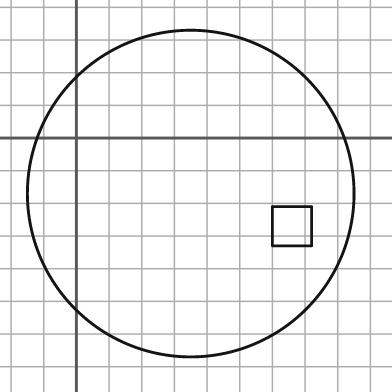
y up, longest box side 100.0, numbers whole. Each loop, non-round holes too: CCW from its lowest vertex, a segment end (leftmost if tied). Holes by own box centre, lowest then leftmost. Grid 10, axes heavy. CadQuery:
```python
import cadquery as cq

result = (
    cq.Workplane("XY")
    .moveTo(35.0, -17.0)
    .circle(50.0)
    .moveTo(60.0, -33.0)
    .lineTo(72.0, -33.0)
    .lineTo(72.0, -21.0)
    .lineTo(60.0, -21.0)
    .close()
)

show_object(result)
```